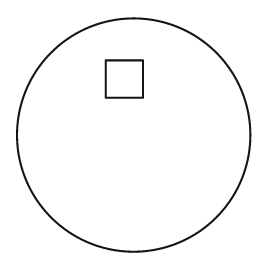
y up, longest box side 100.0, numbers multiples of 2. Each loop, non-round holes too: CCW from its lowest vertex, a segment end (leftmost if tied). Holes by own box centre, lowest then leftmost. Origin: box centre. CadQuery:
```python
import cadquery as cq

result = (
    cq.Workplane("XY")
    .moveTo(0.0, 0.0)
    .circle(50.0)
    .moveTo(-12.0, 16.0)
    .lineTo(4.0, 16.0)
    .lineTo(4.0, 32.0)
    .lineTo(-12.0, 32.0)
    .close()
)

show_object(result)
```